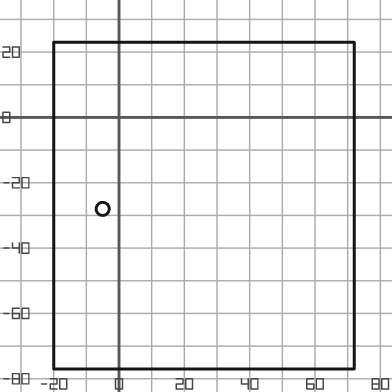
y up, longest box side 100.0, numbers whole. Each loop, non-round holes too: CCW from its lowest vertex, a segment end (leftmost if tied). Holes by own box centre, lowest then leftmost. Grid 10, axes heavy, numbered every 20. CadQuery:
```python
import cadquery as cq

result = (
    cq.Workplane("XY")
    .moveTo(-20.0, -77.0)
    .lineTo(72.0, -77.0)
    .lineTo(72.0, 23.0)
    .lineTo(-20.0, 23.0)
    .close()
    .moveTo(-5.0, -28.0)
    .circle(2.0)
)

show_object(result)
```